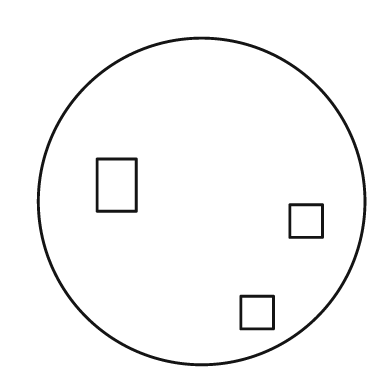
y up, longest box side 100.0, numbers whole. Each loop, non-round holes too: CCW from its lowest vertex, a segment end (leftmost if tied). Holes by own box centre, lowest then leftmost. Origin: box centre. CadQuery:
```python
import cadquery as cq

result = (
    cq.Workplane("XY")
    .moveTo(0.0, 0.0)
    .circle(50.0)
    .moveTo(12.0, -39.0)
    .lineTo(22.0, -39.0)
    .lineTo(22.0, -29.0)
    .lineTo(12.0, -29.0)
    .close()
    .moveTo(27.0, -11.0)
    .lineTo(37.0, -11.0)
    .lineTo(37.0, -1.0)
    .lineTo(27.0, -1.0)
    .close()
    .moveTo(-32.0, -3.0)
    .lineTo(-20.0, -3.0)
    .lineTo(-20.0, 13.0)
    .lineTo(-32.0, 13.0)
    .close()
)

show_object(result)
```